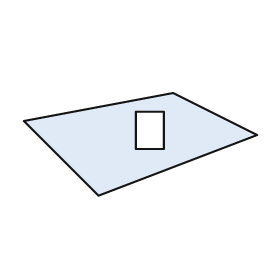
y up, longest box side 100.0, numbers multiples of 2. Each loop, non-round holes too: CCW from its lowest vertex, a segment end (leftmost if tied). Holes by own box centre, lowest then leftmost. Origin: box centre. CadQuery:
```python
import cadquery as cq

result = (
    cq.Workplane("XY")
    .moveTo(-18.0, -22.0)
    .lineTo(50.0, 4.0)
    .lineTo(14.0, 22.0)
    .lineTo(-50.0, 10.0)
    .close()
    .moveTo(-2.0, -2.0)
    .lineTo(10.0, -2.0)
    .lineTo(10.0, 14.0)
    .lineTo(-2.0, 14.0)
    .close()
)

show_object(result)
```